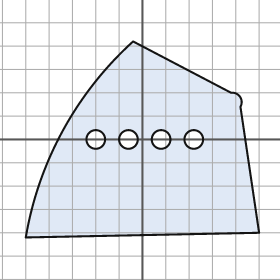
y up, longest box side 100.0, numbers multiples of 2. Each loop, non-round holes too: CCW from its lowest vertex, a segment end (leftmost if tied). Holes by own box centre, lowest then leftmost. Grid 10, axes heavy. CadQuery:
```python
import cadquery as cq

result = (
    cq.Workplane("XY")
    .moveTo(-50.0, -42.0)
    .lineTo(50.0, -40.0)
    .lineTo(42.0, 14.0)
    .threePointArc((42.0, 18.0), (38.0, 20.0))
    .lineTo(-4.0, 42.0)
    .threePointArc((-34.0, 4.0), (-50.0, -42.0))
    .close()
    .moveTo(-20.0, 0.0)
    .circle(4.0)
    .moveTo(-6.0, 0.0)
    .circle(4.0)
    .moveTo(8.0, 0.0)
    .circle(4.0)
    .moveTo(22.0, 0.0)
    .circle(4.0)
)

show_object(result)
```